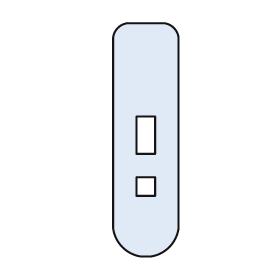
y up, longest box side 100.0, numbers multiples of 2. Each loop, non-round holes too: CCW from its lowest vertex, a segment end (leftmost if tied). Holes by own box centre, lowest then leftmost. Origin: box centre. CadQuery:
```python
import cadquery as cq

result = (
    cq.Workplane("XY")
    .moveTo(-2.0, -50.0)
    .lineTo(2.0, -50.0)
    .threePointArc((10.0, -46.0), (14.0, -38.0))
    .lineTo(14.0, 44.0)
    .threePointArc((12.0, 48.0), (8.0, 50.0))
    .lineTo(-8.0, 50.0)
    .threePointArc((-12.0, 48.0), (-14.0, 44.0))
    .lineTo(-14.0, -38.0)
    .threePointArc((-10.0, -46.0), (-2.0, -50.0))
    .close()
    .moveTo(-4.0, -24.0)
    .lineTo(4.0, -24.0)
    .lineTo(4.0, -16.0)
    .lineTo(-4.0, -16.0)
    .close()
    .moveTo(-4.0, -6.0)
    .lineTo(4.0, -6.0)
    .lineTo(4.0, 10.0)
    .lineTo(-4.0, 10.0)
    .close()
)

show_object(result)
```